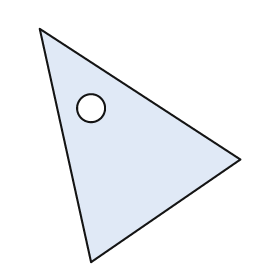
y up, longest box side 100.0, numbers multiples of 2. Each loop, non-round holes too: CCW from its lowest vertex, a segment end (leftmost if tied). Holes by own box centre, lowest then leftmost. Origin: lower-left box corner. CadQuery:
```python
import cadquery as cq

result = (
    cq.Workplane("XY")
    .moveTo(22.0, 0.0)
    .lineTo(86.0, 44.0)
    .lineTo(0.0, 100.0)
    .close()
    .moveTo(22.0, 66.0)
    .circle(6.0)
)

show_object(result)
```